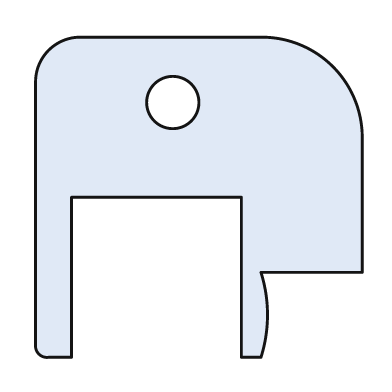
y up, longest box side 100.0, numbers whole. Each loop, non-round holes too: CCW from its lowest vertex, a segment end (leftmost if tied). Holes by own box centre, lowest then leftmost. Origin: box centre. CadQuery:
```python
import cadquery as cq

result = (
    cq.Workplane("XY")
    .moveTo(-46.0, -49.0)
    .lineTo(-39.0, -49.0)
    .lineTo(-39.0, 0.0)
    .lineTo(13.0, 0.0)
    .lineTo(13.0, -49.0)
    .lineTo(19.0, -49.0)
    .threePointArc((21.0, -36.0), (19.0, -23.0))
    .lineTo(50.0, -23.0)
    .lineTo(50.0, 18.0)
    .threePointArc((41.0, 40.0), (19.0, 49.0))
    .lineTo(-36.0, 49.0)
    .threePointArc((-46.0, 45.0), (-50.0, 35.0))
    .lineTo(-50.0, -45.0)
    .threePointArc((-49.0, -48.0), (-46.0, -49.0))
    .close()
    .moveTo(-8.0, 29.0)
    .circle(8.0)
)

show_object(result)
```